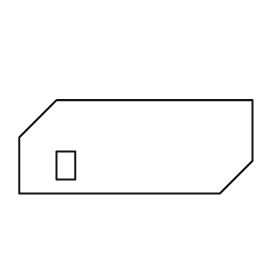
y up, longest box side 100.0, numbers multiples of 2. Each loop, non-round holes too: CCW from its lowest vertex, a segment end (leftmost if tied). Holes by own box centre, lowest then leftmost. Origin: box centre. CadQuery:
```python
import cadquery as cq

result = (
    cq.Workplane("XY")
    .moveTo(-50.0, -20.0)
    .lineTo(36.0, -20.0)
    .lineTo(50.0, -6.0)
    .lineTo(50.0, 20.0)
    .lineTo(-34.0, 20.0)
    .lineTo(-50.0, 4.0)
    .close()
    .moveTo(-34.0, -14.0)
    .lineTo(-26.0, -14.0)
    .lineTo(-26.0, -2.0)
    .lineTo(-34.0, -2.0)
    .close()
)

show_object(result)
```